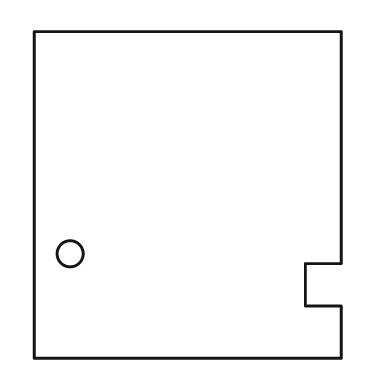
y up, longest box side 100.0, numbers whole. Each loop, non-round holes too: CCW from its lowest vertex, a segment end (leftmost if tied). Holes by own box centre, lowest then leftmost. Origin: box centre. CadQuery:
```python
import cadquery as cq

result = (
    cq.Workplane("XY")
    .moveTo(-47.0, -50.0)
    .lineTo(47.0, -50.0)
    .lineTo(47.0, -34.0)
    .lineTo(36.0, -34.0)
    .lineTo(36.0, -21.0)
    .lineTo(47.0, -21.0)
    .lineTo(47.0, 50.0)
    .lineTo(-47.0, 50.0)
    .close()
    .moveTo(-36.0, -18.0)
    .circle(4.0)
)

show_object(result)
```